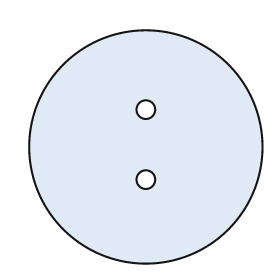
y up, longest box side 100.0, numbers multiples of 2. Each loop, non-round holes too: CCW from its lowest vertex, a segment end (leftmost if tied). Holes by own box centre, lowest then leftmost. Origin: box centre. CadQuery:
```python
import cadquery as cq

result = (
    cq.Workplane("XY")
    .moveTo(0.0, 0.0)
    .circle(50.0)
    .moveTo(0.0, -14.0)
    .circle(4.0)
    .moveTo(0.0, 16.0)
    .circle(4.0)
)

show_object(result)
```